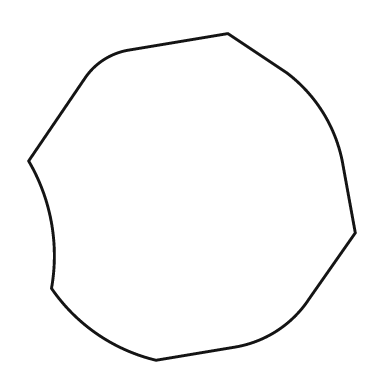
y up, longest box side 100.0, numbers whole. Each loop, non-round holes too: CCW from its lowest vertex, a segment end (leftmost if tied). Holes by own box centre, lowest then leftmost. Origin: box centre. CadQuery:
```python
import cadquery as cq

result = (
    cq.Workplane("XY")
    .moveTo(-11.0, -50.0)
    .lineTo(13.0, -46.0)
    .threePointArc((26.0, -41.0), (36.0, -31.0))
    .lineTo(50.0, -11.0)
    .lineTo(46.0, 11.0)
    .threePointArc((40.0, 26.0), (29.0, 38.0))
    .lineTo(11.0, 50.0)
    .lineTo(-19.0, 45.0)
    .threePointArc((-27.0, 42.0), (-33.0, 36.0))
    .lineTo(-50.0, 11.0)
    .threePointArc((-43.0, -8.0), (-43.0, -28.0))
    .threePointArc((-29.0, -42.0), (-11.0, -50.0))
    .close()
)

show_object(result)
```